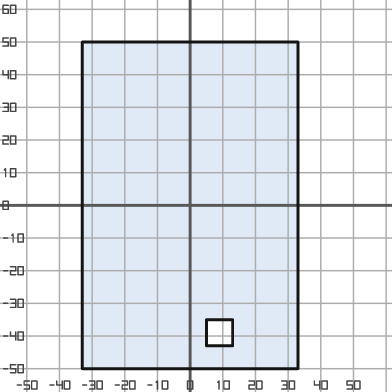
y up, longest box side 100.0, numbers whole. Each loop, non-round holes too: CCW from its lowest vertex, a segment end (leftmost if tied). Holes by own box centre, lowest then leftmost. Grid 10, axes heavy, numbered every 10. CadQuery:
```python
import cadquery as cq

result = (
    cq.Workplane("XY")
    .moveTo(-33.0, -50.0)
    .lineTo(33.0, -50.0)
    .lineTo(33.0, 50.0)
    .lineTo(-33.0, 50.0)
    .close()
    .moveTo(5.0, -43.0)
    .lineTo(13.0, -43.0)
    .lineTo(13.0, -35.0)
    .lineTo(5.0, -35.0)
    .close()
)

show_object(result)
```